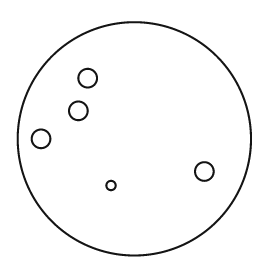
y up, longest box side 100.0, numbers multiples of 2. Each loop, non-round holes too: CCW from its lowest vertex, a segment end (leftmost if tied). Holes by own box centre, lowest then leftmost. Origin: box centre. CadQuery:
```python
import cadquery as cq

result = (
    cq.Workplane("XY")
    .moveTo(0.0, 0.0)
    .circle(50.0)
    .moveTo(-10.0, -20.0)
    .circle(2.0)
    .moveTo(30.0, -14.0)
    .circle(4.0)
    .moveTo(-40.0, 0.0)
    .circle(4.0)
    .moveTo(-24.0, 12.0)
    .circle(4.0)
    .moveTo(-20.0, 26.0)
    .circle(4.0)
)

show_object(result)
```